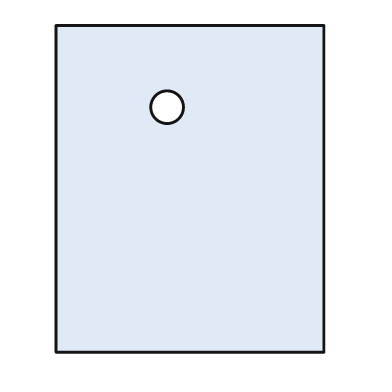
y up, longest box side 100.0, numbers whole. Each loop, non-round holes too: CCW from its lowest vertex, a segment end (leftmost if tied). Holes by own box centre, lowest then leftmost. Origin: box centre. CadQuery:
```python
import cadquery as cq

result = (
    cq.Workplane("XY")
    .moveTo(-41.0, -50.0)
    .lineTo(41.0, -50.0)
    .lineTo(41.0, 50.0)
    .lineTo(-41.0, 50.0)
    .close()
    .moveTo(-7.0, 25.0)
    .circle(5.0)
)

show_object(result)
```